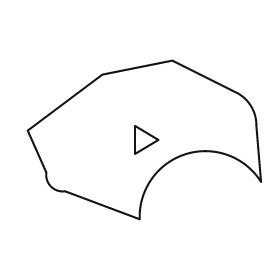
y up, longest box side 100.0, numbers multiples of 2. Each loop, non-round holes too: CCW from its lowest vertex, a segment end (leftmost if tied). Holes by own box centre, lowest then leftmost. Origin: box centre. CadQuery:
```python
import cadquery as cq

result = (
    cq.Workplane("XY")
    .moveTo(-2.0, -34.0)
    .threePointArc((18.0, -6.0), (50.0, -18.0))
    .lineTo(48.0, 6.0)
    .threePointArc((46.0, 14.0), (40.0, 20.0))
    .lineTo(12.0, 34.0)
    .lineTo(-18.0, 28.0)
    .lineTo(-50.0, 4.0)
    .lineTo(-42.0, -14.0)
    .threePointArc((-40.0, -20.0), (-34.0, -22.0))
    .close()
    .moveTo(-4.0, -6.0)
    .lineTo(6.0, 0.0)
    .lineTo(-4.0, 6.0)
    .close()
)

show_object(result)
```